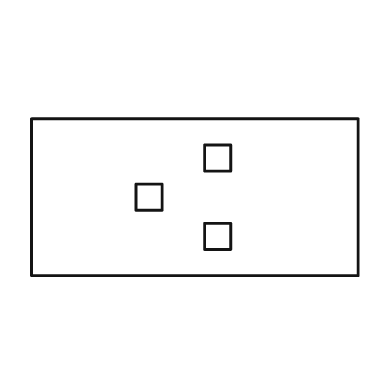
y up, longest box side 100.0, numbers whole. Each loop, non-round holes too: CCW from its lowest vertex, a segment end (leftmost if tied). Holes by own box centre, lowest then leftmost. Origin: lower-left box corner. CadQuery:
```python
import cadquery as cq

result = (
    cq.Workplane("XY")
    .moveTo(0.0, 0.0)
    .lineTo(100.0, 0.0)
    .lineTo(100.0, 48.0)
    .lineTo(0.0, 48.0)
    .close()
    .moveTo(53.0, 8.0)
    .lineTo(61.0, 8.0)
    .lineTo(61.0, 16.0)
    .lineTo(53.0, 16.0)
    .close()
    .moveTo(32.0, 20.0)
    .lineTo(40.0, 20.0)
    .lineTo(40.0, 28.0)
    .lineTo(32.0, 28.0)
    .close()
    .moveTo(53.0, 32.0)
    .lineTo(61.0, 32.0)
    .lineTo(61.0, 40.0)
    .lineTo(53.0, 40.0)
    .close()
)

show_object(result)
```